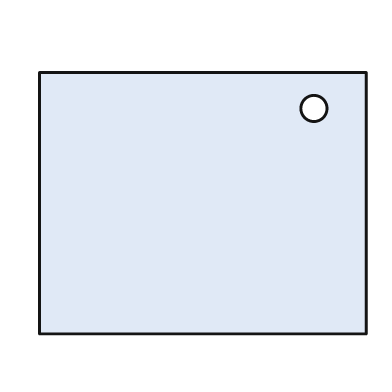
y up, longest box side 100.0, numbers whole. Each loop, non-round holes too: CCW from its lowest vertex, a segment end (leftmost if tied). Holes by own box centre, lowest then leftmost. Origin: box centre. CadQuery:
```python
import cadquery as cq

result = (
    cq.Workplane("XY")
    .moveTo(-50.0, -40.0)
    .lineTo(50.0, -40.0)
    .lineTo(50.0, 40.0)
    .lineTo(-50.0, 40.0)
    .close()
    .moveTo(34.0, 29.0)
    .circle(4.0)
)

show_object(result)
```